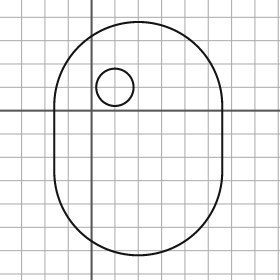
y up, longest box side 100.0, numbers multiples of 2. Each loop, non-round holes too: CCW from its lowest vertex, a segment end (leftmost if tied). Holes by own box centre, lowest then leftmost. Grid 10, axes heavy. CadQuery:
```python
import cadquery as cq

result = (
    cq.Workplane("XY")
    .moveTo(-16.0, -26.0)
    .threePointArc((20.0, -62.0), (56.0, -26.0))
    .lineTo(56.0, 2.0)
    .threePointArc((20.0, 38.0), (-16.0, 2.0))
    .close()
    .moveTo(10.0, 10.0)
    .circle(8.0)
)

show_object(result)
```